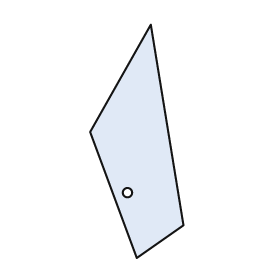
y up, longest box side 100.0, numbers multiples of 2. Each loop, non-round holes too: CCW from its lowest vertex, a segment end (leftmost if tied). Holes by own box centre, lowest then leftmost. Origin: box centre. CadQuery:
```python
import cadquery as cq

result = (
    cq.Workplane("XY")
    .moveTo(0.0, -50.0)
    .lineTo(20.0, -36.0)
    .lineTo(6.0, 50.0)
    .lineTo(-20.0, 4.0)
    .close()
    .moveTo(-4.0, -22.0)
    .circle(2.0)
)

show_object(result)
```